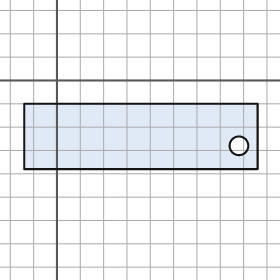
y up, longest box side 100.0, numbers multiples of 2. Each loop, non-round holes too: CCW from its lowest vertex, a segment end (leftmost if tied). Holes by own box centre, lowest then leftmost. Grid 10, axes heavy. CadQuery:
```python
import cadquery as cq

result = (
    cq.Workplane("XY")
    .moveTo(-14.0, -38.0)
    .lineTo(86.0, -38.0)
    .lineTo(86.0, -10.0)
    .lineTo(-14.0, -10.0)
    .close()
    .moveTo(78.0, -28.0)
    .circle(4.0)
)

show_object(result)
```